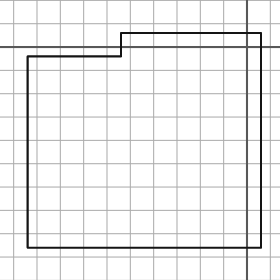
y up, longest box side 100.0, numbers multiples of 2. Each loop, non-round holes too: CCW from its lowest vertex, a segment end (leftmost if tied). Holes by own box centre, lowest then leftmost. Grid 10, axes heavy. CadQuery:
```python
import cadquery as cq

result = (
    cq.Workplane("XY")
    .moveTo(-94.0, -86.0)
    .lineTo(6.0, -86.0)
    .lineTo(6.0, 6.0)
    .lineTo(-54.0, 6.0)
    .lineTo(-54.0, -4.0)
    .lineTo(-94.0, -4.0)
    .close()
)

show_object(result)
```